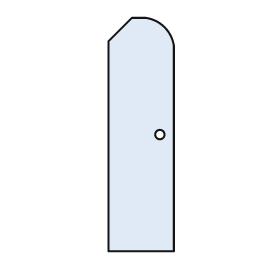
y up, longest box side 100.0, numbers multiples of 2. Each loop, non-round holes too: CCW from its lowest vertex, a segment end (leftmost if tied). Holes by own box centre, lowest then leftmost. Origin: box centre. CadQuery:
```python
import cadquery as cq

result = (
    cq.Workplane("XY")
    .moveTo(-14.0, -50.0)
    .lineTo(14.0, -50.0)
    .lineTo(14.0, 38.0)
    .threePointArc((10.0, 46.0), (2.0, 50.0))
    .lineTo(-4.0, 50.0)
    .lineTo(-14.0, 40.0)
    .close()
    .moveTo(8.0, 0.0)
    .circle(2.0)
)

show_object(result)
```